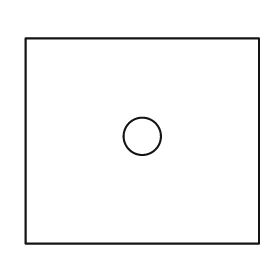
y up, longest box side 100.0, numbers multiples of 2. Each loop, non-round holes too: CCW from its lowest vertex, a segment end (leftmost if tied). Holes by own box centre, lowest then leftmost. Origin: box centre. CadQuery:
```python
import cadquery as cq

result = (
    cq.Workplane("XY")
    .moveTo(-50.0, -44.0)
    .lineTo(50.0, -44.0)
    .lineTo(50.0, 44.0)
    .lineTo(-50.0, 44.0)
    .close()
    .moveTo(0.0, 2.0)
    .circle(8.0)
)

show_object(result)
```